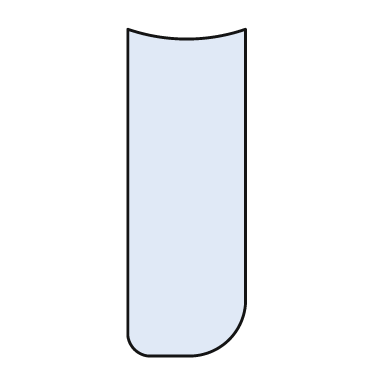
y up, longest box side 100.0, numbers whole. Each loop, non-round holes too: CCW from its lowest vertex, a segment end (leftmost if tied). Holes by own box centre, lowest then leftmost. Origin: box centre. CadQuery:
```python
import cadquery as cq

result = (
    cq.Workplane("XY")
    .moveTo(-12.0, -50.0)
    .lineTo(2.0, -50.0)
    .threePointArc((13.0, -45.0), (18.0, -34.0))
    .lineTo(18.0, 50.0)
    .threePointArc((0.0, 47.0), (-18.0, 50.0))
    .lineTo(-18.0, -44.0)
    .threePointArc((-16.0, -48.0), (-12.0, -50.0))
    .close()
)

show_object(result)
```